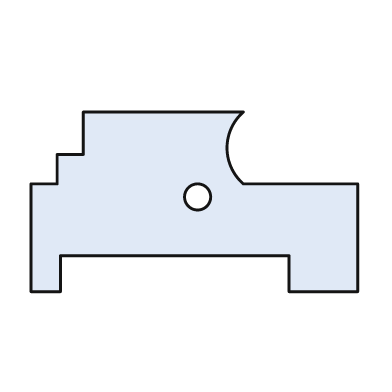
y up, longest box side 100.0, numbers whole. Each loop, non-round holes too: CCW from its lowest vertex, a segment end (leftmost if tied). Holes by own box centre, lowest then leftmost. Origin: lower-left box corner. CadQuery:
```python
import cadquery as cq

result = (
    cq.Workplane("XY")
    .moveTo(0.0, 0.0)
    .lineTo(9.0, 0.0)
    .lineTo(9.0, 11.0)
    .lineTo(79.0, 11.0)
    .lineTo(79.0, 0.0)
    .lineTo(100.0, 0.0)
    .lineTo(100.0, 33.0)
    .lineTo(65.0, 33.0)
    .threePointArc((60.0, 44.0), (65.0, 55.0))
    .lineTo(16.0, 55.0)
    .lineTo(16.0, 42.0)
    .lineTo(8.0, 42.0)
    .lineTo(8.0, 33.0)
    .lineTo(0.0, 33.0)
    .close()
    .moveTo(51.0, 29.0)
    .circle(4.0)
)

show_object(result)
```